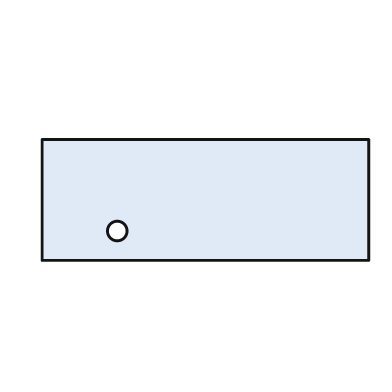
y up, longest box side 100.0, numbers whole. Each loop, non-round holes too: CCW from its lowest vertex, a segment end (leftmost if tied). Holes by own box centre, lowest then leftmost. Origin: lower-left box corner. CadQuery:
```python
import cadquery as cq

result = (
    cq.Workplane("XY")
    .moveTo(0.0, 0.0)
    .lineTo(100.0, 0.0)
    .lineTo(100.0, 37.0)
    .lineTo(0.0, 37.0)
    .close()
    .moveTo(23.0, 9.0)
    .circle(3.0)
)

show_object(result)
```